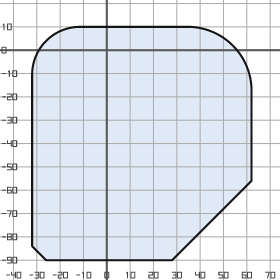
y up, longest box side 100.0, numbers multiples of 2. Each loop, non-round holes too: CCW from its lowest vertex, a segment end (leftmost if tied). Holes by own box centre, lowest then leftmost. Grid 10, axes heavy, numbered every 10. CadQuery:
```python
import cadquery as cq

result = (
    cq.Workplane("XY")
    .moveTo(-26.0, -90.0)
    .lineTo(28.0, -90.0)
    .lineTo(62.0, -56.0)
    .lineTo(62.0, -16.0)
    .threePointArc((54.0, 2.0), (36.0, 10.0))
    .lineTo(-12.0, 10.0)
    .threePointArc((-26.0, 4.0), (-32.0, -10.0))
    .lineTo(-32.0, -84.0)
    .close()
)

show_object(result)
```